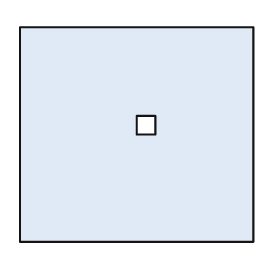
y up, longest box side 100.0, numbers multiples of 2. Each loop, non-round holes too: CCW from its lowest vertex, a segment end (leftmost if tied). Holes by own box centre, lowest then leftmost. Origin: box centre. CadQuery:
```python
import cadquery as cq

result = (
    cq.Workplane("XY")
    .moveTo(-50.0, -46.0)
    .lineTo(50.0, -46.0)
    .lineTo(50.0, 46.0)
    .lineTo(-50.0, 46.0)
    .close()
    .moveTo(0.0, 0.0)
    .lineTo(8.0, 0.0)
    .lineTo(8.0, 8.0)
    .lineTo(0.0, 8.0)
    .close()
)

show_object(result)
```